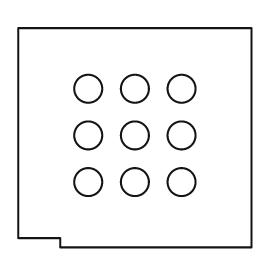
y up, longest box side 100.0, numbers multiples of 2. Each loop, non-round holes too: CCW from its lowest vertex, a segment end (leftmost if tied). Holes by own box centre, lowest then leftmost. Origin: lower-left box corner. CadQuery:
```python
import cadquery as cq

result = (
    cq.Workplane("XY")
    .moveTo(18.0, 0.0)
    .lineTo(100.0, 0.0)
    .lineTo(100.0, 94.0)
    .lineTo(0.0, 94.0)
    .lineTo(0.0, 4.0)
    .lineTo(18.0, 4.0)
    .close()
    .moveTo(30.0, 28.0)
    .circle(6.0)
    .moveTo(50.0, 28.0)
    .circle(6.0)
    .moveTo(70.0, 28.0)
    .circle(6.0)
    .moveTo(30.0, 48.0)
    .circle(6.0)
    .moveTo(50.0, 48.0)
    .circle(6.0)
    .moveTo(70.0, 48.0)
    .circle(6.0)
    .moveTo(30.0, 68.0)
    .circle(6.0)
    .moveTo(50.0, 68.0)
    .circle(6.0)
    .moveTo(70.0, 68.0)
    .circle(6.0)
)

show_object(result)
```